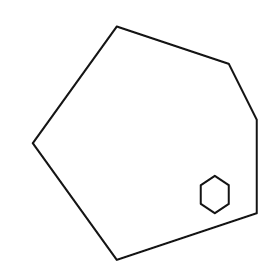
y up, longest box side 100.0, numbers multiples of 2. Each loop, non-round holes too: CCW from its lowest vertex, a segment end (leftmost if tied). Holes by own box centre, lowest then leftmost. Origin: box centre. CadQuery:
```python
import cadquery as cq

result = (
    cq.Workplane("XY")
    .moveTo(-12.0, -50.0)
    .lineTo(48.0, -30.0)
    .lineTo(48.0, 10.0)
    .lineTo(36.0, 34.0)
    .lineTo(-12.0, 50.0)
    .lineTo(-48.0, 0.0)
    .close()
    .moveTo(30.0, -30.0)
    .lineTo(36.0, -26.0)
    .lineTo(36.0, -18.0)
    .lineTo(30.0, -14.0)
    .lineTo(24.0, -18.0)
    .lineTo(24.0, -26.0)
    .close()
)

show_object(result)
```